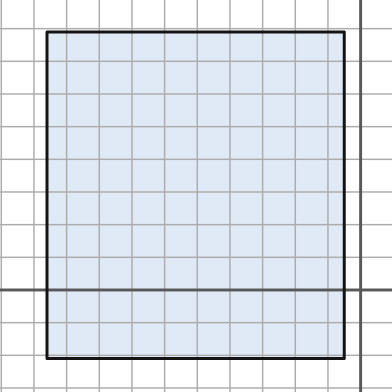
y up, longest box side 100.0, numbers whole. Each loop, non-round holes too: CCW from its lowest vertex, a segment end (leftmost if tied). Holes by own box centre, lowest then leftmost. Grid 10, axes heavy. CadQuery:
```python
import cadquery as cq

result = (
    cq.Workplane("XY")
    .moveTo(-96.0, -21.0)
    .lineTo(-5.0, -21.0)
    .lineTo(-5.0, 79.0)
    .lineTo(-96.0, 79.0)
    .close()
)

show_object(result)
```